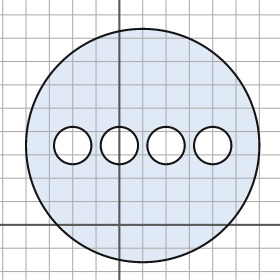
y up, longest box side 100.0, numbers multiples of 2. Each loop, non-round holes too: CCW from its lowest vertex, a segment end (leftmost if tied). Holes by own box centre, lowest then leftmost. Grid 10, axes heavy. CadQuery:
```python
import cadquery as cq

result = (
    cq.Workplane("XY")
    .moveTo(10.0, 34.0)
    .circle(50.0)
    .moveTo(-20.0, 34.0)
    .circle(8.0)
    .moveTo(0.0, 34.0)
    .circle(8.0)
    .moveTo(20.0, 34.0)
    .circle(8.0)
    .moveTo(40.0, 34.0)
    .circle(8.0)
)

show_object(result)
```